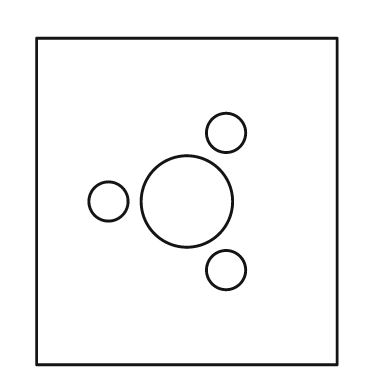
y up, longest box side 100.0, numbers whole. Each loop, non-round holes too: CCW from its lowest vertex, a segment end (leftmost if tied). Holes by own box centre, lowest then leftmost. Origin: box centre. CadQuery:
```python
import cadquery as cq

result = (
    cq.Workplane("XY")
    .moveTo(-46.0, -50.0)
    .lineTo(46.0, -50.0)
    .lineTo(46.0, 50.0)
    .lineTo(-46.0, 50.0)
    .close()
    .moveTo(12.0, -21.0)
    .circle(6.0)
    .moveTo(-24.0, 0.0)
    .circle(6.0)
    .moveTo(0.0, 0.0)
    .circle(14.0)
    .moveTo(12.0, 21.0)
    .circle(6.0)
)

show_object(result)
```